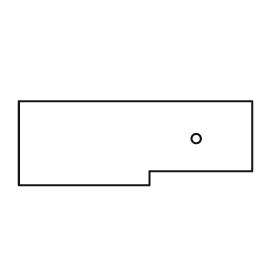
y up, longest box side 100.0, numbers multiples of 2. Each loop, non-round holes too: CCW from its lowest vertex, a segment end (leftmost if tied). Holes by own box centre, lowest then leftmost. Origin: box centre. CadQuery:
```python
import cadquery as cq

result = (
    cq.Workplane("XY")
    .moveTo(-50.0, -18.0)
    .lineTo(6.0, -18.0)
    .lineTo(6.0, -12.0)
    .lineTo(50.0, -12.0)
    .lineTo(50.0, 18.0)
    .lineTo(-50.0, 18.0)
    .close()
    .moveTo(26.0, 2.0)
    .circle(2.0)
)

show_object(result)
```